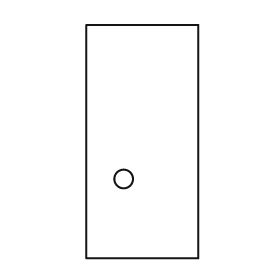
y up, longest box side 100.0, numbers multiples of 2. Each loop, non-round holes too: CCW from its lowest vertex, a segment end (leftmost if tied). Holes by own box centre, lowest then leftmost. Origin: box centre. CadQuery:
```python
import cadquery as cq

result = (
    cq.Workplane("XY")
    .moveTo(-24.0, -50.0)
    .lineTo(24.0, -50.0)
    .lineTo(24.0, 50.0)
    .lineTo(-24.0, 50.0)
    .close()
    .moveTo(-8.0, -16.0)
    .circle(4.0)
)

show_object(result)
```